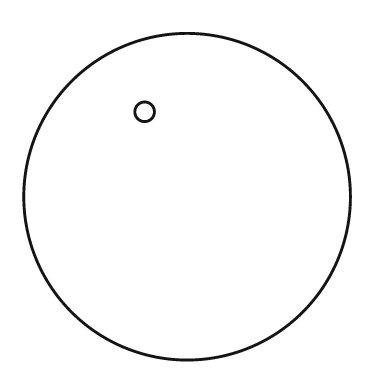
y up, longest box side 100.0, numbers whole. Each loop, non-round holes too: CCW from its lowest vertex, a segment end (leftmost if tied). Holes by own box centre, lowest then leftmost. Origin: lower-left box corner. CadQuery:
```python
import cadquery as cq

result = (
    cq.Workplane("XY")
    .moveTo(50.0, 50.0)
    .circle(50.0)
    .moveTo(37.0, 76.0)
    .circle(3.0)
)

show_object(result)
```